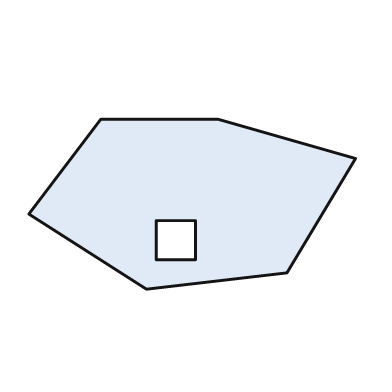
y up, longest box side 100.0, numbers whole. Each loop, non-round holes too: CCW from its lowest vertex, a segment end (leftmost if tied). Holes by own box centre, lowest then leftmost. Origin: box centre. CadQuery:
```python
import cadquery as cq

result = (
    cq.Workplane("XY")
    .moveTo(-14.0, -26.0)
    .lineTo(29.0, -21.0)
    .lineTo(50.0, 14.0)
    .lineTo(8.0, 26.0)
    .lineTo(-28.0, 26.0)
    .lineTo(-50.0, -3.0)
    .close()
    .moveTo(-11.0, -17.0)
    .lineTo(1.0, -17.0)
    .lineTo(1.0, -5.0)
    .lineTo(-11.0, -5.0)
    .close()
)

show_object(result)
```